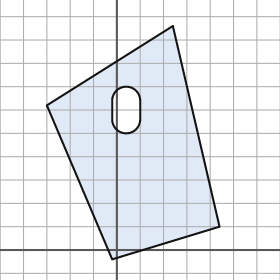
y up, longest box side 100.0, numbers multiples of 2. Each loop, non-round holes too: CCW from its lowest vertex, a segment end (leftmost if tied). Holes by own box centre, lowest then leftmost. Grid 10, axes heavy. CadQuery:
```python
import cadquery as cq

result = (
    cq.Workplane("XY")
    .moveTo(-2.0, -4.0)
    .lineTo(44.0, 10.0)
    .lineTo(24.0, 96.0)
    .lineTo(-30.0, 62.0)
    .close()
    .moveTo(-2.0, 56.0)
    .threePointArc((4.0, 50.0), (10.0, 56.0))
    .lineTo(10.0, 64.0)
    .threePointArc((4.0, 70.0), (-2.0, 64.0))
    .close()
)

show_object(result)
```